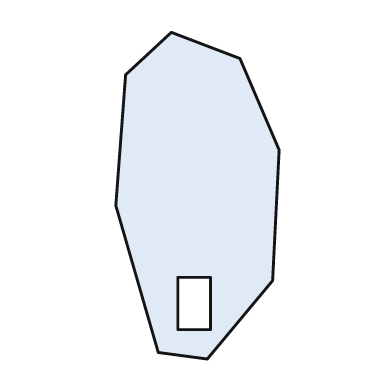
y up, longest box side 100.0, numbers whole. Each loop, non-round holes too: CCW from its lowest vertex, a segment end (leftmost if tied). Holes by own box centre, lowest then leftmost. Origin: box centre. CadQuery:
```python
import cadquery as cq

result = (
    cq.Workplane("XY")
    .moveTo(3.0, -50.0)
    .lineTo(23.0, -26.0)
    .lineTo(25.0, 14.0)
    .lineTo(13.0, 42.0)
    .lineTo(-8.0, 50.0)
    .lineTo(-22.0, 37.0)
    .lineTo(-25.0, -3.0)
    .lineTo(-12.0, -48.0)
    .close()
    .moveTo(-6.0, -41.0)
    .lineTo(4.0, -41.0)
    .lineTo(4.0, -25.0)
    .lineTo(-6.0, -25.0)
    .close()
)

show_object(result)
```